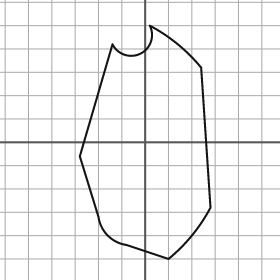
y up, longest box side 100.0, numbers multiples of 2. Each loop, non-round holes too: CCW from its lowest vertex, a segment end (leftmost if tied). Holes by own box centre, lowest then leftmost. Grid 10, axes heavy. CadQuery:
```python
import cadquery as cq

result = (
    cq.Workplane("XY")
    .moveTo(10.0, -50.0)
    .threePointArc((20.0, -40.0), (28.0, -28.0))
    .lineTo(24.0, 32.0)
    .threePointArc((14.0, 42.0), (2.0, 50.0))
    .threePointArc((-2.0, 38.0), (-14.0, 42.0))
    .lineTo(-28.0, -6.0)
    .lineTo(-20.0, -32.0)
    .threePointArc((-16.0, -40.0), (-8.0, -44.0))
    .close()
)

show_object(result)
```